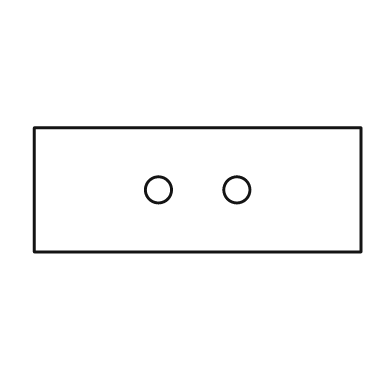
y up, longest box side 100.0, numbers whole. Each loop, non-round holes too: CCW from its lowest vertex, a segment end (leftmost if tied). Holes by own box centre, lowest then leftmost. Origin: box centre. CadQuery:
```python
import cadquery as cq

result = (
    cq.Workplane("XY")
    .moveTo(-50.0, -19.0)
    .lineTo(50.0, -19.0)
    .lineTo(50.0, 19.0)
    .lineTo(-50.0, 19.0)
    .close()
    .moveTo(-12.0, 0.0)
    .circle(4.0)
    .moveTo(12.0, 0.0)
    .circle(4.0)
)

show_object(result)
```